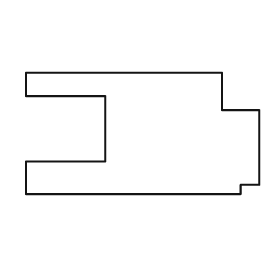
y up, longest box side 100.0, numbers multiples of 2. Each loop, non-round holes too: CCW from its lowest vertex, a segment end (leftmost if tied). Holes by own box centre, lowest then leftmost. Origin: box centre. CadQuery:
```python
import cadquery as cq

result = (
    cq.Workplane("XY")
    .moveTo(-50.0, -26.0)
    .lineTo(42.0, -26.0)
    .lineTo(42.0, -22.0)
    .lineTo(50.0, -22.0)
    .lineTo(50.0, 10.0)
    .lineTo(34.0, 10.0)
    .lineTo(34.0, 26.0)
    .lineTo(-50.0, 26.0)
    .lineTo(-50.0, 16.0)
    .lineTo(-16.0, 16.0)
    .lineTo(-16.0, -12.0)
    .lineTo(-50.0, -12.0)
    .close()
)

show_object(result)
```